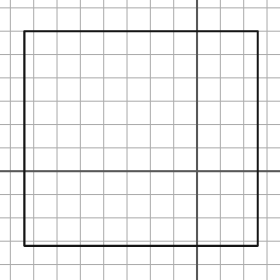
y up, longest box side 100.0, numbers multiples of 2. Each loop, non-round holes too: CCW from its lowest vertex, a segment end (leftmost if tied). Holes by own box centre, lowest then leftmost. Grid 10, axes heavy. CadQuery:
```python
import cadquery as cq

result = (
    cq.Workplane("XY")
    .moveTo(-74.0, -32.0)
    .lineTo(26.0, -32.0)
    .lineTo(26.0, 60.0)
    .lineTo(-74.0, 60.0)
    .close()
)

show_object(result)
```